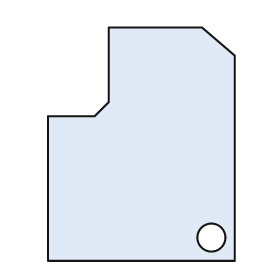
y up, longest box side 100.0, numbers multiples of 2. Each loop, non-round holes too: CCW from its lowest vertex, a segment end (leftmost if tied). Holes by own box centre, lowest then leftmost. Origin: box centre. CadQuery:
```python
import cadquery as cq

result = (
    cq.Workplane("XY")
    .moveTo(-40.0, -50.0)
    .lineTo(40.0, -50.0)
    .lineTo(40.0, 38.0)
    .lineTo(26.0, 50.0)
    .lineTo(-14.0, 50.0)
    .lineTo(-14.0, 18.0)
    .lineTo(-20.0, 12.0)
    .lineTo(-40.0, 12.0)
    .close()
    .moveTo(30.0, -40.0)
    .circle(6.0)
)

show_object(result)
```